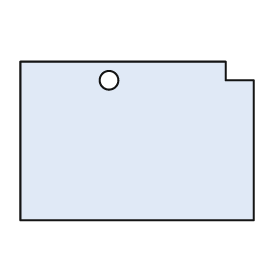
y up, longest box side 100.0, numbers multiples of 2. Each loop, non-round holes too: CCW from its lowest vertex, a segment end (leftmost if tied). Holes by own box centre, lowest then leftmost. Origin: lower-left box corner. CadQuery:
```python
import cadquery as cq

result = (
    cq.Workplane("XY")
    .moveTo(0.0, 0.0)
    .lineTo(100.0, 0.0)
    .lineTo(100.0, 60.0)
    .lineTo(88.0, 60.0)
    .lineTo(88.0, 68.0)
    .lineTo(0.0, 68.0)
    .close()
    .moveTo(38.0, 60.0)
    .circle(4.0)
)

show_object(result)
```